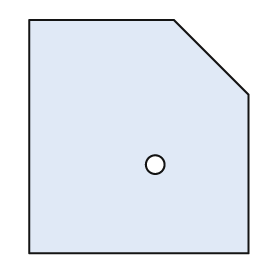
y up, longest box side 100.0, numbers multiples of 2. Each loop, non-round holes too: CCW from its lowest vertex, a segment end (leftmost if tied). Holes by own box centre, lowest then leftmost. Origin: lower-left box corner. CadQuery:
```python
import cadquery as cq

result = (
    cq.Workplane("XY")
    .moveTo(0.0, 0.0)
    .lineTo(94.0, 0.0)
    .lineTo(94.0, 68.0)
    .lineTo(62.0, 100.0)
    .lineTo(0.0, 100.0)
    .close()
    .moveTo(54.0, 38.0)
    .circle(4.0)
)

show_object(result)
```